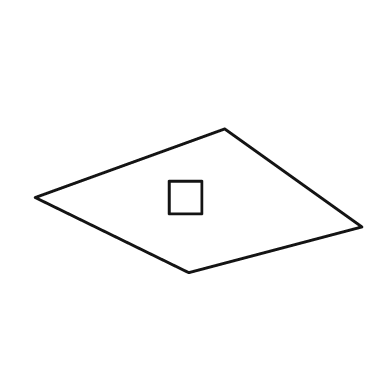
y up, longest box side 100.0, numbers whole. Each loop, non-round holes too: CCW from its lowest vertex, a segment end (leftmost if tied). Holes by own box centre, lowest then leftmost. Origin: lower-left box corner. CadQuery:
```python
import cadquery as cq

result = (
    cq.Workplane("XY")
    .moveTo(47.0, 0.0)
    .lineTo(100.0, 14.0)
    .lineTo(58.0, 44.0)
    .lineTo(0.0, 23.0)
    .close()
    .moveTo(41.0, 18.0)
    .lineTo(51.0, 18.0)
    .lineTo(51.0, 28.0)
    .lineTo(41.0, 28.0)
    .close()
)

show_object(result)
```